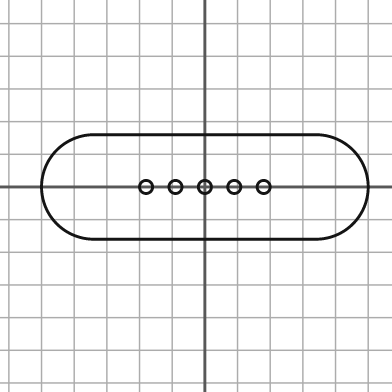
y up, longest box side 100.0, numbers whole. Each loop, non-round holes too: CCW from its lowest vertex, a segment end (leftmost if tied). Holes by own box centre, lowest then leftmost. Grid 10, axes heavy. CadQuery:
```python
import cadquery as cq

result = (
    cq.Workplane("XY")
    .moveTo(-34.0, -16.0)
    .lineTo(34.0, -16.0)
    .threePointArc((50.0, 0.0), (34.0, 16.0))
    .lineTo(-34.0, 16.0)
    .threePointArc((-50.0, 0.0), (-34.0, -16.0))
    .close()
    .moveTo(-18.0, 0.0)
    .circle(2.0)
    .moveTo(-9.0, 0.0)
    .circle(2.0)
    .moveTo(0.0, 0.0)
    .circle(2.0)
    .moveTo(9.0, 0.0)
    .circle(2.0)
    .moveTo(18.0, 0.0)
    .circle(2.0)
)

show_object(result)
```